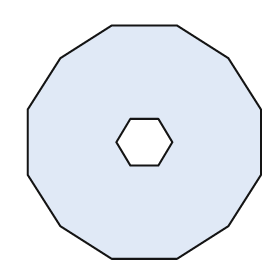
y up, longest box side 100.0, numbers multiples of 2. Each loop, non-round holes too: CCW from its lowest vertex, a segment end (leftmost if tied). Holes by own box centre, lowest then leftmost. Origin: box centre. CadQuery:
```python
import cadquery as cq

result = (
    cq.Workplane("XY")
    .moveTo(-14.0, -50.0)
    .lineTo(14.0, -50.0)
    .lineTo(36.0, -36.0)
    .lineTo(50.0, -14.0)
    .lineTo(50.0, 14.0)
    .lineTo(36.0, 36.0)
    .lineTo(14.0, 50.0)
    .lineTo(-14.0, 50.0)
    .lineTo(-36.0, 36.0)
    .lineTo(-50.0, 14.0)
    .lineTo(-50.0, -14.0)
    .lineTo(-36.0, -36.0)
    .close()
    .moveTo(-6.0, -10.0)
    .lineTo(6.0, -10.0)
    .lineTo(12.0, 0.0)
    .lineTo(6.0, 10.0)
    .lineTo(-6.0, 10.0)
    .lineTo(-12.0, 0.0)
    .close()
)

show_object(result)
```